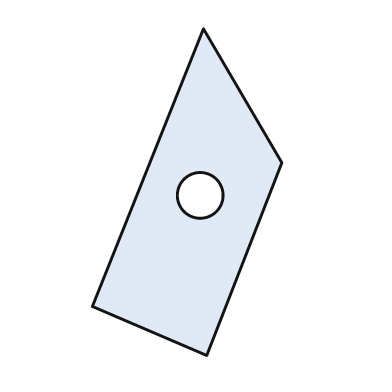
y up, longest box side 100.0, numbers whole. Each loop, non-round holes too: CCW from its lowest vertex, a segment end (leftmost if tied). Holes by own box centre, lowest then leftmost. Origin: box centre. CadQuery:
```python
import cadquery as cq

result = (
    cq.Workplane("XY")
    .moveTo(6.0, -50.0)
    .lineTo(29.0, 9.0)
    .lineTo(5.0, 50.0)
    .lineTo(-29.0, -35.0)
    .close()
    .moveTo(4.0, -1.0)
    .circle(7.0)
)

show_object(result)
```